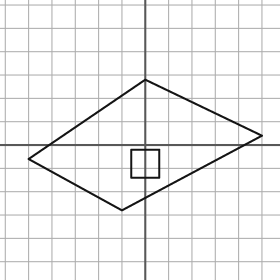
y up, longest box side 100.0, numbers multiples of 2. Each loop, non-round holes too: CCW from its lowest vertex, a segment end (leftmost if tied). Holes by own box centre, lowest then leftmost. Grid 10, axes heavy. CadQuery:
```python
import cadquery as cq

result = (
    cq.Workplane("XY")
    .moveTo(-10.0, -28.0)
    .lineTo(50.0, 4.0)
    .lineTo(0.0, 28.0)
    .lineTo(-50.0, -6.0)
    .close()
    .moveTo(-6.0, -14.0)
    .lineTo(6.0, -14.0)
    .lineTo(6.0, -2.0)
    .lineTo(-6.0, -2.0)
    .close()
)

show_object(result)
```